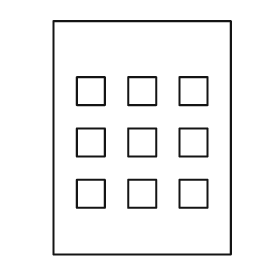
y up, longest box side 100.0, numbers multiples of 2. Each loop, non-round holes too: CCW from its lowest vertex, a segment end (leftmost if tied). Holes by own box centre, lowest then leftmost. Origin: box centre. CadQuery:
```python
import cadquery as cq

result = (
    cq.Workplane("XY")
    .moveTo(-38.0, -50.0)
    .lineTo(38.0, -50.0)
    .lineTo(38.0, 50.0)
    .lineTo(-38.0, 50.0)
    .close()
    .moveTo(-28.0, -30.0)
    .lineTo(-16.0, -30.0)
    .lineTo(-16.0, -18.0)
    .lineTo(-28.0, -18.0)
    .close()
    .moveTo(-6.0, -30.0)
    .lineTo(6.0, -30.0)
    .lineTo(6.0, -18.0)
    .lineTo(-6.0, -18.0)
    .close()
    .moveTo(16.0, -30.0)
    .lineTo(28.0, -30.0)
    .lineTo(28.0, -18.0)
    .lineTo(16.0, -18.0)
    .close()
    .moveTo(-28.0, -8.0)
    .lineTo(-16.0, -8.0)
    .lineTo(-16.0, 4.0)
    .lineTo(-28.0, 4.0)
    .close()
    .moveTo(-6.0, -8.0)
    .lineTo(6.0, -8.0)
    .lineTo(6.0, 4.0)
    .lineTo(-6.0, 4.0)
    .close()
    .moveTo(16.0, -8.0)
    .lineTo(28.0, -8.0)
    .lineTo(28.0, 4.0)
    .lineTo(16.0, 4.0)
    .close()
    .moveTo(-28.0, 14.0)
    .lineTo(-16.0, 14.0)
    .lineTo(-16.0, 26.0)
    .lineTo(-28.0, 26.0)
    .close()
    .moveTo(-6.0, 14.0)
    .lineTo(6.0, 14.0)
    .lineTo(6.0, 26.0)
    .lineTo(-6.0, 26.0)
    .close()
    .moveTo(16.0, 14.0)
    .lineTo(28.0, 14.0)
    .lineTo(28.0, 26.0)
    .lineTo(16.0, 26.0)
    .close()
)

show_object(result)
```